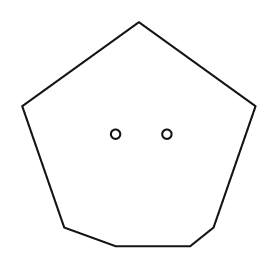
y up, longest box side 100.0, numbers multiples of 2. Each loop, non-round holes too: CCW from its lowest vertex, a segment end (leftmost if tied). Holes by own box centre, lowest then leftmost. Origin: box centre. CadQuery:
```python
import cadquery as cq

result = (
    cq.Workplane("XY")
    .moveTo(-10.0, -48.0)
    .lineTo(22.0, -48.0)
    .lineTo(32.0, -40.0)
    .lineTo(50.0, 12.0)
    .lineTo(0.0, 48.0)
    .lineTo(-50.0, 12.0)
    .lineTo(-32.0, -40.0)
    .close()
    .moveTo(-10.0, 0.0)
    .circle(2.0)
    .moveTo(12.0, 0.0)
    .circle(2.0)
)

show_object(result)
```